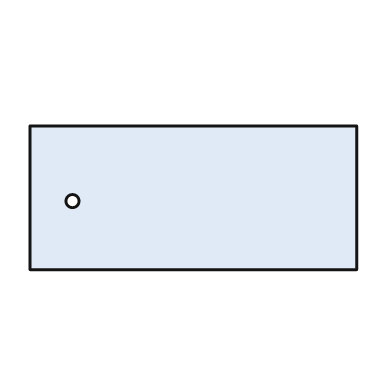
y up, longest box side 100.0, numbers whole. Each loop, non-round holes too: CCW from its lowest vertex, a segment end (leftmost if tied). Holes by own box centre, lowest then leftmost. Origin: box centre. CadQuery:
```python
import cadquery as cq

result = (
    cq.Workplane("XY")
    .moveTo(-50.0, -22.0)
    .lineTo(50.0, -22.0)
    .lineTo(50.0, 22.0)
    .lineTo(-50.0, 22.0)
    .close()
    .moveTo(-37.0, -1.0)
    .circle(2.0)
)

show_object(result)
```